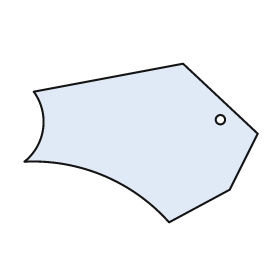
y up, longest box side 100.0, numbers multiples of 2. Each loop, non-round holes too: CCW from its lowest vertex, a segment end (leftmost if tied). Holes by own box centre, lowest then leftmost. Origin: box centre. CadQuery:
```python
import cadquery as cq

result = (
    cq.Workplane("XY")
    .moveTo(12.0, -34.0)
    .lineTo(38.0, -20.0)
    .lineTo(50.0, 4.0)
    .lineTo(18.0, 34.0)
    .lineTo(-46.0, 22.0)
    .threePointArc((-42.0, 6.0), (-50.0, -8.0))
    .threePointArc((-16.0, -14.0), (12.0, -34.0))
    .close()
    .moveTo(34.0, 10.0)
    .circle(2.0)
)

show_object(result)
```